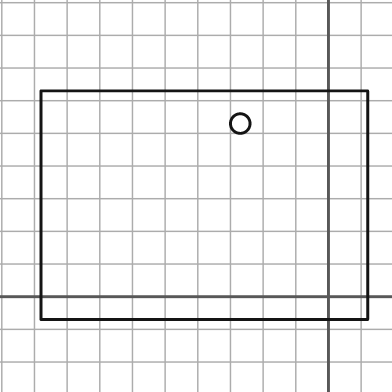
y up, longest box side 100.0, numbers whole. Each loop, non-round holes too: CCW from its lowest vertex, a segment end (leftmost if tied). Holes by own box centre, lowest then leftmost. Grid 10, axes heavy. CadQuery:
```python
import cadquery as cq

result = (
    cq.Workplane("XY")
    .moveTo(-88.0, -7.0)
    .lineTo(12.0, -7.0)
    .lineTo(12.0, 63.0)
    .lineTo(-88.0, 63.0)
    .close()
    .moveTo(-27.0, 53.0)
    .circle(3.0)
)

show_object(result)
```